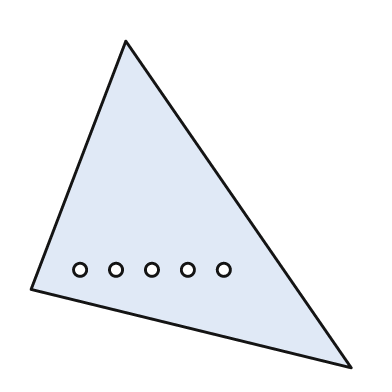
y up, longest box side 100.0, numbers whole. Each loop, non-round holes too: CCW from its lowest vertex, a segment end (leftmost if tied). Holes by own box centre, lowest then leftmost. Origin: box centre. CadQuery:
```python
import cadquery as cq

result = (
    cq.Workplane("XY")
    .moveTo(49.0, -50.0)
    .lineTo(-20.0, 50.0)
    .lineTo(-49.0, -26.0)
    .close()
    .moveTo(-34.0, -20.0)
    .circle(2.0)
    .moveTo(-23.0, -20.0)
    .circle(2.0)
    .moveTo(-12.0, -20.0)
    .circle(2.0)
    .moveTo(-1.0, -20.0)
    .circle(2.0)
    .moveTo(10.0, -20.0)
    .circle(2.0)
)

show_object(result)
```